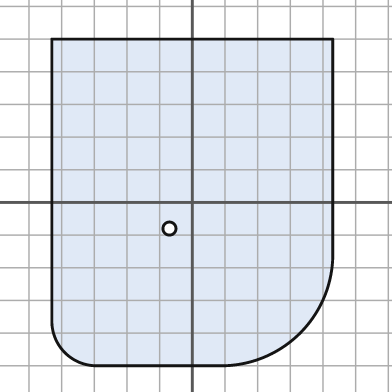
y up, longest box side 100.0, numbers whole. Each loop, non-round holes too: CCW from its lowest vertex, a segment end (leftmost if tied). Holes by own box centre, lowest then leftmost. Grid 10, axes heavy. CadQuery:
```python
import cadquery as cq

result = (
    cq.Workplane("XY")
    .moveTo(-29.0, -50.0)
    .lineTo(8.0, -50.0)
    .threePointArc((33.0, -40.0), (43.0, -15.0))
    .lineTo(43.0, 50.0)
    .lineTo(-43.0, 50.0)
    .lineTo(-43.0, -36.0)
    .threePointArc((-39.0, -46.0), (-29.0, -50.0))
    .close()
    .moveTo(-7.0, -8.0)
    .circle(2.0)
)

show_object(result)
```